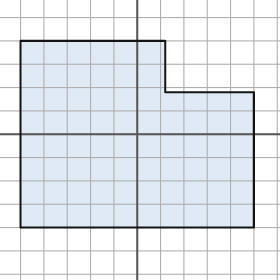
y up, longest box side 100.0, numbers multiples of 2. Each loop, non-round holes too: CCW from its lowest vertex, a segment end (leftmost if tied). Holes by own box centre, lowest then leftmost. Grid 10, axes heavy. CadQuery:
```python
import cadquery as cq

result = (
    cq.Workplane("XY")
    .moveTo(-50.0, -40.0)
    .lineTo(50.0, -40.0)
    .lineTo(50.0, 18.0)
    .lineTo(12.0, 18.0)
    .lineTo(12.0, 40.0)
    .lineTo(-50.0, 40.0)
    .close()
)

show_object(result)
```